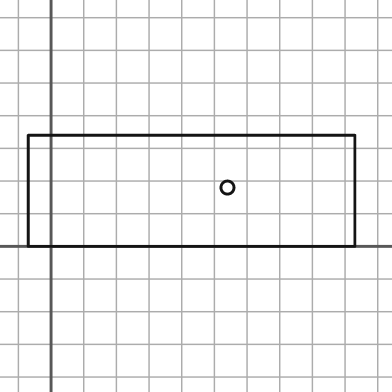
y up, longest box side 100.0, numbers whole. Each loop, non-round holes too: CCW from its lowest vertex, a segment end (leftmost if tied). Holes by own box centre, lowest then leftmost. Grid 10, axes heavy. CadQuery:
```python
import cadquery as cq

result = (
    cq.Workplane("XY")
    .moveTo(-7.0, 0.0)
    .lineTo(93.0, 0.0)
    .lineTo(93.0, 34.0)
    .lineTo(-7.0, 34.0)
    .close()
    .moveTo(54.0, 18.0)
    .circle(2.0)
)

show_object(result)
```